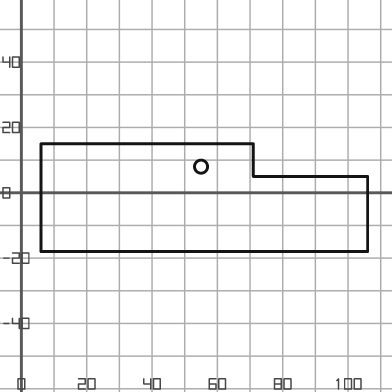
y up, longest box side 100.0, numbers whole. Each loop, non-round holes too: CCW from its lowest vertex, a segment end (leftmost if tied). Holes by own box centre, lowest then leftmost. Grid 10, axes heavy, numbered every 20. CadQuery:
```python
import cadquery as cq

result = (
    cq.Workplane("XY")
    .moveTo(6.0, -18.0)
    .lineTo(106.0, -18.0)
    .lineTo(106.0, 5.0)
    .lineTo(71.0, 5.0)
    .lineTo(71.0, 15.0)
    .lineTo(6.0, 15.0)
    .close()
    .moveTo(55.0, 8.0)
    .circle(2.0)
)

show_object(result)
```